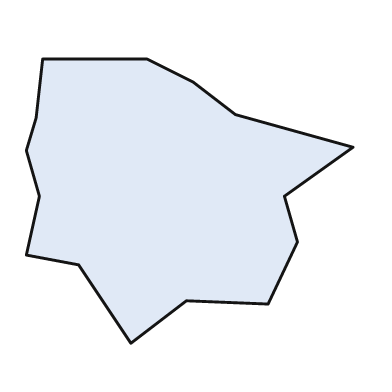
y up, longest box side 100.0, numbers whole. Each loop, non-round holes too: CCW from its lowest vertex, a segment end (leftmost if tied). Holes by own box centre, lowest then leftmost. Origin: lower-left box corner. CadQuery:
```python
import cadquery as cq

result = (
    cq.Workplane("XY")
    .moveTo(32.0, 0.0)
    .lineTo(49.0, 13.0)
    .lineTo(74.0, 12.0)
    .lineTo(83.0, 31.0)
    .lineTo(79.0, 45.0)
    .lineTo(100.0, 60.0)
    .lineTo(64.0, 70.0)
    .lineTo(51.0, 80.0)
    .lineTo(37.0, 87.0)
    .lineTo(5.0, 87.0)
    .lineTo(3.0, 69.0)
    .lineTo(0.0, 59.0)
    .lineTo(4.0, 45.0)
    .lineTo(0.0, 27.0)
    .lineTo(16.0, 24.0)
    .close()
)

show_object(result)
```